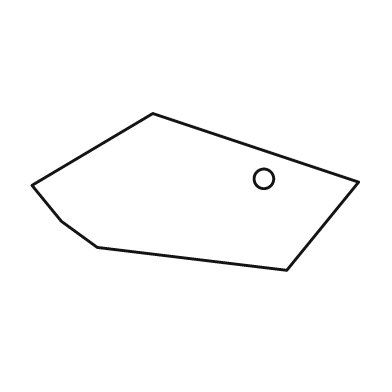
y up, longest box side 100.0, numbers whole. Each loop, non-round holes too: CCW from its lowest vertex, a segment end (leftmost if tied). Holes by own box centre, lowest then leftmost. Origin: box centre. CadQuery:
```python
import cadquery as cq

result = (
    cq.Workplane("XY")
    .moveTo(28.0, -24.0)
    .lineTo(50.0, 3.0)
    .lineTo(-13.0, 24.0)
    .lineTo(-50.0, 2.0)
    .lineTo(-41.0, -9.0)
    .lineTo(-30.0, -17.0)
    .close()
    .moveTo(21.0, 4.0)
    .circle(3.0)
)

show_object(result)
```